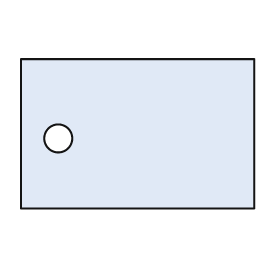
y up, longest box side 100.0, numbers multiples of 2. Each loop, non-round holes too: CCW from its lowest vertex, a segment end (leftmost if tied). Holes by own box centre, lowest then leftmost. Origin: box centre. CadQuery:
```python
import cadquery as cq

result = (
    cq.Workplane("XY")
    .moveTo(-50.0, -32.0)
    .lineTo(50.0, -32.0)
    .lineTo(50.0, 32.0)
    .lineTo(-50.0, 32.0)
    .close()
    .moveTo(-34.0, -2.0)
    .circle(6.0)
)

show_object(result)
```